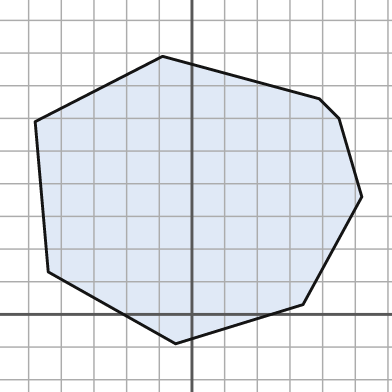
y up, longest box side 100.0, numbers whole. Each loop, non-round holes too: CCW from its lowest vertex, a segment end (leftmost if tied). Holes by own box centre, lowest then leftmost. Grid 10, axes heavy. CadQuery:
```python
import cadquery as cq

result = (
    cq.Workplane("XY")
    .moveTo(-5.0, -9.0)
    .lineTo(34.0, 3.0)
    .lineTo(52.0, 36.0)
    .lineTo(45.0, 60.0)
    .lineTo(39.0, 66.0)
    .lineTo(-9.0, 79.0)
    .lineTo(-48.0, 59.0)
    .lineTo(-44.0, 13.0)
    .close()
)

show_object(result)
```